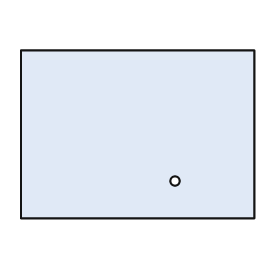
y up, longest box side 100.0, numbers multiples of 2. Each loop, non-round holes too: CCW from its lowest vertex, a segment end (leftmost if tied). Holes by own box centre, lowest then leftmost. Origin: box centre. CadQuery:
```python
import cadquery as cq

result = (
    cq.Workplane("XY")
    .moveTo(-50.0, -36.0)
    .lineTo(50.0, -36.0)
    .lineTo(50.0, 36.0)
    .lineTo(-50.0, 36.0)
    .close()
    .moveTo(16.0, -20.0)
    .circle(2.0)
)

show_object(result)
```